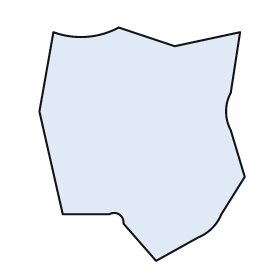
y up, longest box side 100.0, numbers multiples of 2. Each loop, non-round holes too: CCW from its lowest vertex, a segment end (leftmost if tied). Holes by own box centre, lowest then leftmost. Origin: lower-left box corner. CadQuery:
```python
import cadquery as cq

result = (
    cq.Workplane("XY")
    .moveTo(50.0, 0.0)
    .lineTo(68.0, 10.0)
    .threePointArc((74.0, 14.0), (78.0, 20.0))
    .lineTo(88.0, 36.0)
    .lineTo(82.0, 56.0)
    .threePointArc((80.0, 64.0), (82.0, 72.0))
    .lineTo(86.0, 98.0)
    .lineTo(58.0, 92.0)
    .lineTo(34.0, 100.0)
    .threePointArc((20.0, 96.0), (6.0, 98.0))
    .lineTo(0.0, 64.0)
    .lineTo(10.0, 20.0)
    .lineTo(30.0, 20.0)
    .threePointArc((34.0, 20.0), (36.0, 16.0))
    .close()
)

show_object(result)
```